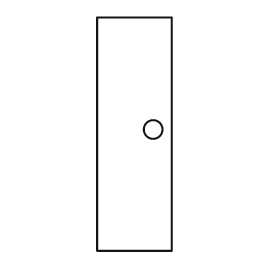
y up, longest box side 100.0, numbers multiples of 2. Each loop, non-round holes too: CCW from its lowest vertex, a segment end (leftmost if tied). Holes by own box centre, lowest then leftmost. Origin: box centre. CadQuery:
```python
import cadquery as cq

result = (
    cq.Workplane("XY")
    .moveTo(-16.0, -50.0)
    .lineTo(16.0, -50.0)
    .lineTo(16.0, 50.0)
    .lineTo(-16.0, 50.0)
    .close()
    .moveTo(8.0, 2.0)
    .circle(4.0)
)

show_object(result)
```